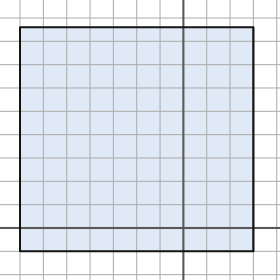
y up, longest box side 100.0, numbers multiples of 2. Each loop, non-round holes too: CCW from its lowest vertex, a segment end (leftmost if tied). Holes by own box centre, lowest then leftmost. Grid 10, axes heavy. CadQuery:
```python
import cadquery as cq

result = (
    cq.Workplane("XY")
    .moveTo(-70.0, -10.0)
    .lineTo(30.0, -10.0)
    .lineTo(30.0, 86.0)
    .lineTo(-70.0, 86.0)
    .close()
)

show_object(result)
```